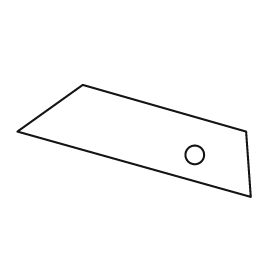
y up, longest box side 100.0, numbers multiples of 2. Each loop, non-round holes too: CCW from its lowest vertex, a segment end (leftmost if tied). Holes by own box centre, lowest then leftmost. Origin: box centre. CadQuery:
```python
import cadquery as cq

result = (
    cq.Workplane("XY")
    .moveTo(50.0, -24.0)
    .lineTo(48.0, 4.0)
    .lineTo(-22.0, 24.0)
    .lineTo(-50.0, 4.0)
    .close()
    .moveTo(26.0, -6.0)
    .circle(4.0)
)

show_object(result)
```